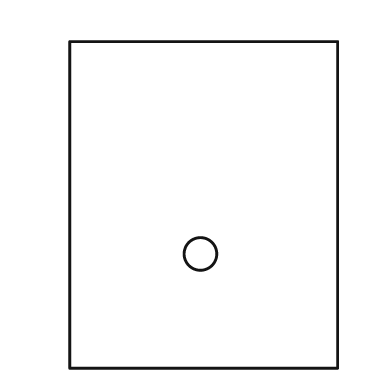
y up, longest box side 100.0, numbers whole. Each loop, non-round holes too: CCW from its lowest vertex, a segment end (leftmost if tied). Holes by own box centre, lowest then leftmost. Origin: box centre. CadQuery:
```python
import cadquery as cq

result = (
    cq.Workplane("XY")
    .moveTo(-41.0, -50.0)
    .lineTo(41.0, -50.0)
    .lineTo(41.0, 50.0)
    .lineTo(-41.0, 50.0)
    .close()
    .moveTo(-1.0, -15.0)
    .circle(5.0)
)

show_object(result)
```